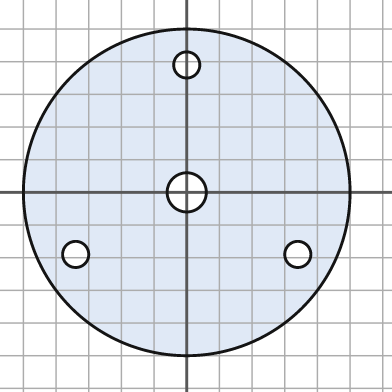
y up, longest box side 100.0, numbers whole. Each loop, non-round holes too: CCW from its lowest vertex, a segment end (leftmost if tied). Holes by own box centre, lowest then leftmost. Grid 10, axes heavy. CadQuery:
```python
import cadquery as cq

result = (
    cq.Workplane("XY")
    .moveTo(0.0, 0.0)
    .circle(50.0)
    .moveTo(-34.0, -19.0)
    .circle(4.0)
    .moveTo(34.0, -19.0)
    .circle(4.0)
    .moveTo(0.0, 0.0)
    .circle(6.0)
    .moveTo(0.0, 39.0)
    .circle(4.0)
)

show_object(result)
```